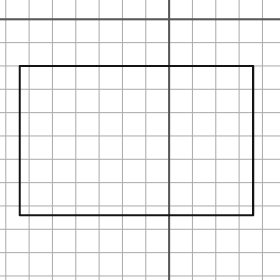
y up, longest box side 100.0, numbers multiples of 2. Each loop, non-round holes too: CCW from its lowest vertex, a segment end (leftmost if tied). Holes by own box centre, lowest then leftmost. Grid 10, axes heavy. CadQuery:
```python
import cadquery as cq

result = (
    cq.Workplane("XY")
    .moveTo(-64.0, -84.0)
    .lineTo(36.0, -84.0)
    .lineTo(36.0, -20.0)
    .lineTo(-64.0, -20.0)
    .close()
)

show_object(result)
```